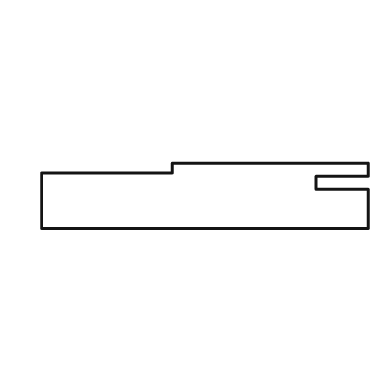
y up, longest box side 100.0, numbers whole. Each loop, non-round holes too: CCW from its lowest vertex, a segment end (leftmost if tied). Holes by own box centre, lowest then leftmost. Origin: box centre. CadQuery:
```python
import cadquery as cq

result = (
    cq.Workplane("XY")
    .moveTo(-50.0, -10.0)
    .lineTo(50.0, -10.0)
    .lineTo(50.0, 2.0)
    .lineTo(34.0, 2.0)
    .lineTo(34.0, 6.0)
    .lineTo(50.0, 6.0)
    .lineTo(50.0, 10.0)
    .lineTo(-10.0, 10.0)
    .lineTo(-10.0, 7.0)
    .lineTo(-50.0, 7.0)
    .close()
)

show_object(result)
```